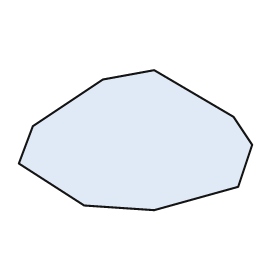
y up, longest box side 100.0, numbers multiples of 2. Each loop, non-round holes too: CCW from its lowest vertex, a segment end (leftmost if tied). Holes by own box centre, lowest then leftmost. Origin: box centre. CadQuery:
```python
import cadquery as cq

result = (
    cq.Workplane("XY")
    .moveTo(8.0, -30.0)
    .lineTo(44.0, -20.0)
    .lineTo(50.0, -2.0)
    .lineTo(42.0, 10.0)
    .lineTo(8.0, 30.0)
    .lineTo(-14.0, 26.0)
    .lineTo(-44.0, 6.0)
    .lineTo(-50.0, -10.0)
    .lineTo(-22.0, -28.0)
    .close()
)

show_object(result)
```